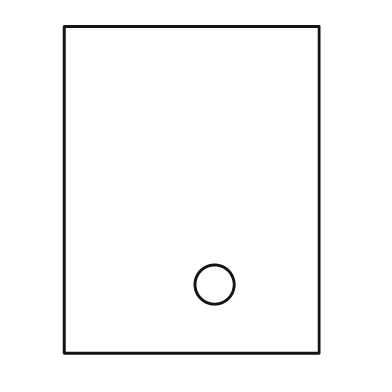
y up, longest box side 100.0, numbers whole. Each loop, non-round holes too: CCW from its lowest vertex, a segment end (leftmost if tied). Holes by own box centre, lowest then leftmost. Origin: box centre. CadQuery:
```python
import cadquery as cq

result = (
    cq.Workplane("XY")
    .moveTo(-39.0, -50.0)
    .lineTo(39.0, -50.0)
    .lineTo(39.0, 50.0)
    .lineTo(-39.0, 50.0)
    .close()
    .moveTo(7.0, -29.0)
    .circle(6.0)
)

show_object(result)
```